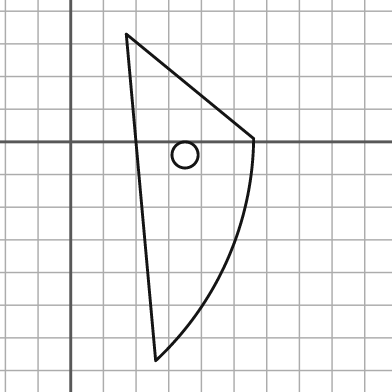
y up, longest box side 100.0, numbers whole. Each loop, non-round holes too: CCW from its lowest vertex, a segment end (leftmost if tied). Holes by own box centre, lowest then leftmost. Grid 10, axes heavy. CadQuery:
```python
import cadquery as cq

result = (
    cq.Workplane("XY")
    .moveTo(26.0, -67.0)
    .threePointArc((48.0, -36.0), (56.0, 1.0))
    .lineTo(17.0, 33.0)
    .close()
    .moveTo(35.0, -4.0)
    .circle(4.0)
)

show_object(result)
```